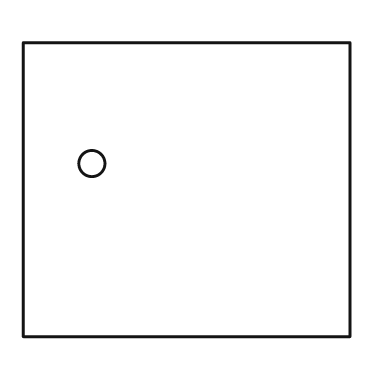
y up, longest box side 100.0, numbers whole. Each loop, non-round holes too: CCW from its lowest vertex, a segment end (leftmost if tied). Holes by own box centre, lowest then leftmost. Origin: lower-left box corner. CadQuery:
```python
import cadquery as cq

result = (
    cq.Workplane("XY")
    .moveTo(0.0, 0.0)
    .lineTo(100.0, 0.0)
    .lineTo(100.0, 90.0)
    .lineTo(0.0, 90.0)
    .close()
    .moveTo(21.0, 53.0)
    .circle(4.0)
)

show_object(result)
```